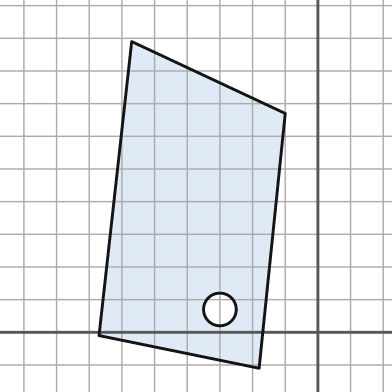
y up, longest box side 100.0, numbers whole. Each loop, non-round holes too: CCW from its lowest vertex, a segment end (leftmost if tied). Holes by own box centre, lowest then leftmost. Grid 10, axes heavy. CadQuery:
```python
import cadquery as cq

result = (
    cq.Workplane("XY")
    .moveTo(-18.0, -11.0)
    .lineTo(-10.0, 67.0)
    .lineTo(-57.0, 89.0)
    .lineTo(-67.0, -1.0)
    .close()
    .moveTo(-30.0, 7.0)
    .circle(5.0)
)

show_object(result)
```